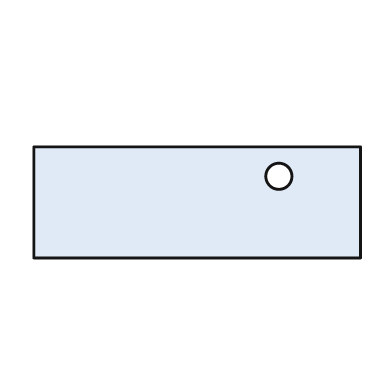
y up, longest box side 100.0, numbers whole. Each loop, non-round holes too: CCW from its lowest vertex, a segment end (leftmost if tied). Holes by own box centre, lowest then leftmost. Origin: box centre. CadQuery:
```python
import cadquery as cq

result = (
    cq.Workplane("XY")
    .moveTo(-50.0, -17.0)
    .lineTo(50.0, -17.0)
    .lineTo(50.0, 17.0)
    .lineTo(-50.0, 17.0)
    .close()
    .moveTo(25.0, 8.0)
    .circle(4.0)
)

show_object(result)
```